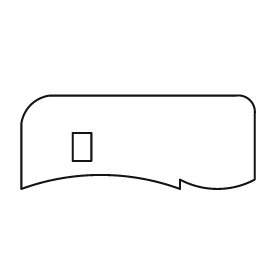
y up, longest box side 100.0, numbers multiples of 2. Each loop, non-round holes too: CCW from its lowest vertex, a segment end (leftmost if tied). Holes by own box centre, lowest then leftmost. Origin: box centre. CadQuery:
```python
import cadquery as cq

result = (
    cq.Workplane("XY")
    .moveTo(-50.0, -20.0)
    .threePointArc((-16.0, -14.0), (18.0, -20.0))
    .lineTo(18.0, -16.0)
    .threePointArc((34.0, -20.0), (50.0, -16.0))
    .lineTo(50.0, 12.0)
    .threePointArc((48.0, 18.0), (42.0, 20.0))
    .lineTo(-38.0, 20.0)
    .threePointArc((-46.0, 16.0), (-50.0, 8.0))
    .close()
    .moveTo(-28.0, -8.0)
    .lineTo(-20.0, -8.0)
    .lineTo(-20.0, 4.0)
    .lineTo(-28.0, 4.0)
    .close()
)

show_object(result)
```